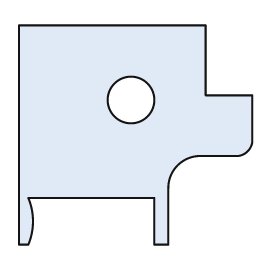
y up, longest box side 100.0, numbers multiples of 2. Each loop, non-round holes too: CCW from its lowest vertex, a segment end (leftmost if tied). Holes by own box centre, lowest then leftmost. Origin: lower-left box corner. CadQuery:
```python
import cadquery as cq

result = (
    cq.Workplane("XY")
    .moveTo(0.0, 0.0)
    .lineTo(4.0, 0.0)
    .threePointArc((6.0, 10.0), (4.0, 20.0))
    .lineTo(58.0, 20.0)
    .lineTo(58.0, 0.0)
    .lineTo(64.0, 0.0)
    .lineTo(64.0, 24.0)
    .threePointArc((68.0, 34.0), (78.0, 38.0))
    .lineTo(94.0, 38.0)
    .threePointArc((98.0, 40.0), (100.0, 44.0))
    .lineTo(100.0, 64.0)
    .lineTo(80.0, 64.0)
    .lineTo(80.0, 94.0)
    .lineTo(0.0, 94.0)
    .close()
    .moveTo(48.0, 62.0)
    .circle(10.0)
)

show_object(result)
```